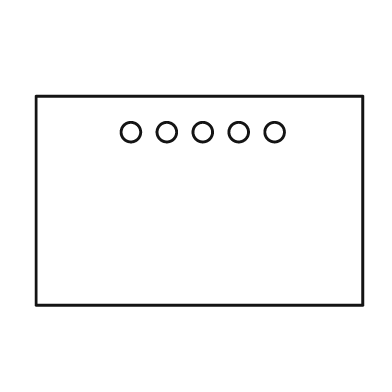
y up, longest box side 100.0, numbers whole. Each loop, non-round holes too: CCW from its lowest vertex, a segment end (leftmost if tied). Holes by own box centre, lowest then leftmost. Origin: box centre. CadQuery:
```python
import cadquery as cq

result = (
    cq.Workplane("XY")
    .moveTo(-50.0, -32.0)
    .lineTo(50.0, -32.0)
    .lineTo(50.0, 32.0)
    .lineTo(-50.0, 32.0)
    .close()
    .moveTo(-21.0, 21.0)
    .circle(3.0)
    .moveTo(-10.0, 21.0)
    .circle(3.0)
    .moveTo(1.0, 21.0)
    .circle(3.0)
    .moveTo(12.0, 21.0)
    .circle(3.0)
    .moveTo(23.0, 21.0)
    .circle(3.0)
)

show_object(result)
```